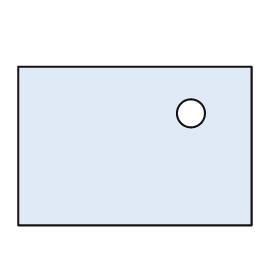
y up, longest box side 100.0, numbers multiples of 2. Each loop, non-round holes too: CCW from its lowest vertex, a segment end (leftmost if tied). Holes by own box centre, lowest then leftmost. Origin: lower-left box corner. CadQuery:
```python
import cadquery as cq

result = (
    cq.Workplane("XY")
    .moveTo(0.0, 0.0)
    .lineTo(100.0, 0.0)
    .lineTo(100.0, 68.0)
    .lineTo(0.0, 68.0)
    .close()
    .moveTo(74.0, 48.0)
    .circle(6.0)
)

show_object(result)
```